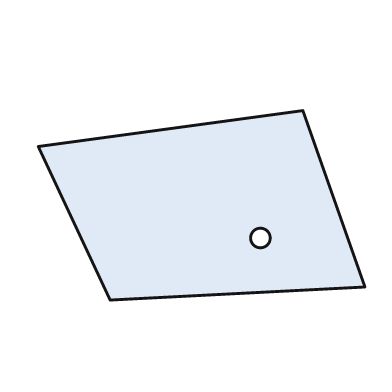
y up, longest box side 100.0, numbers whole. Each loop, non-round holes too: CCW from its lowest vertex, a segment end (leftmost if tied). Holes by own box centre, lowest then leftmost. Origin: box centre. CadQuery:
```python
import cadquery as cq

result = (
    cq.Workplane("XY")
    .moveTo(-28.0, -29.0)
    .lineTo(50.0, -25.0)
    .lineTo(31.0, 29.0)
    .lineTo(-50.0, 18.0)
    .close()
    .moveTo(18.0, -10.0)
    .circle(3.0)
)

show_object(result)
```